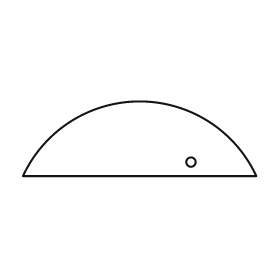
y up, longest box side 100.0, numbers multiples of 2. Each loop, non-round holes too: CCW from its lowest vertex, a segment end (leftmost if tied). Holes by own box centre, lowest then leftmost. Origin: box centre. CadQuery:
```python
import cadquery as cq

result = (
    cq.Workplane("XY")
    .moveTo(-50.0, -16.0)
    .lineTo(50.0, -16.0)
    .threePointArc((0.0, 16.0), (-50.0, -16.0))
    .close()
    .moveTo(22.0, -10.0)
    .circle(2.0)
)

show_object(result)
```